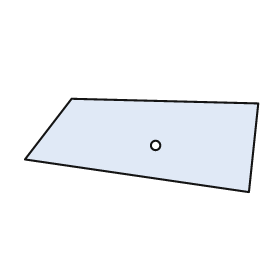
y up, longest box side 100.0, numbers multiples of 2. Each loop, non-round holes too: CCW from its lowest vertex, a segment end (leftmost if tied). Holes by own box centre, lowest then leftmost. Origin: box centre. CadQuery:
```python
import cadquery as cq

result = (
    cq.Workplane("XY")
    .moveTo(46.0, -20.0)
    .lineTo(50.0, 18.0)
    .lineTo(-30.0, 20.0)
    .lineTo(-50.0, -6.0)
    .close()
    .moveTo(6.0, 0.0)
    .circle(2.0)
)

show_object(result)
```